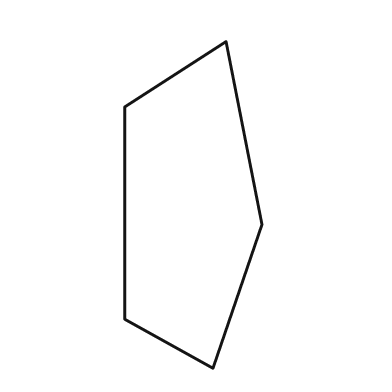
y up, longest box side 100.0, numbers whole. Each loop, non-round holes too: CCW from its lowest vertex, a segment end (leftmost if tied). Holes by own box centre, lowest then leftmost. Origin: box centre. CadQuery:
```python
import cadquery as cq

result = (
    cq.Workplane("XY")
    .moveTo(6.0, -50.0)
    .lineTo(21.0, -6.0)
    .lineTo(10.0, 50.0)
    .lineTo(-21.0, 30.0)
    .lineTo(-21.0, -35.0)
    .close()
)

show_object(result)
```